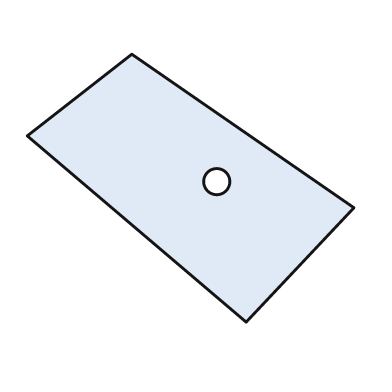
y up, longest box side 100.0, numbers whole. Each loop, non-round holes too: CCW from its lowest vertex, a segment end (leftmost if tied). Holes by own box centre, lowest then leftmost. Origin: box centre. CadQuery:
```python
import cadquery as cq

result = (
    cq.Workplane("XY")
    .moveTo(17.0, -41.0)
    .lineTo(50.0, -6.0)
    .lineTo(-18.0, 41.0)
    .lineTo(-50.0, 16.0)
    .close()
    .moveTo(8.0, 2.0)
    .circle(4.0)
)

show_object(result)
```